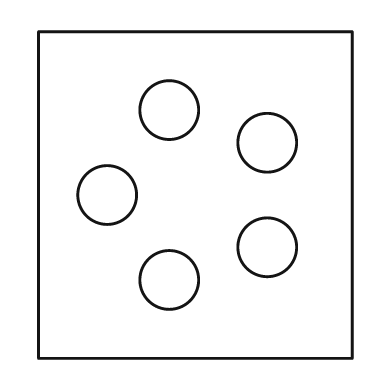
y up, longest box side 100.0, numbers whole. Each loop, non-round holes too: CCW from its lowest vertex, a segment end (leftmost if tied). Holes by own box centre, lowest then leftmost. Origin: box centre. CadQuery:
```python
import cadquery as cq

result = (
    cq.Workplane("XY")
    .moveTo(-48.0, -50.0)
    .lineTo(48.0, -50.0)
    .lineTo(48.0, 50.0)
    .lineTo(-48.0, 50.0)
    .close()
    .moveTo(-8.0, -26.0)
    .circle(9.0)
    .moveTo(22.0, -16.0)
    .circle(9.0)
    .moveTo(-27.0, 0.0)
    .circle(9.0)
    .moveTo(22.0, 16.0)
    .circle(9.0)
    .moveTo(-8.0, 26.0)
    .circle(9.0)
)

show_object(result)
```